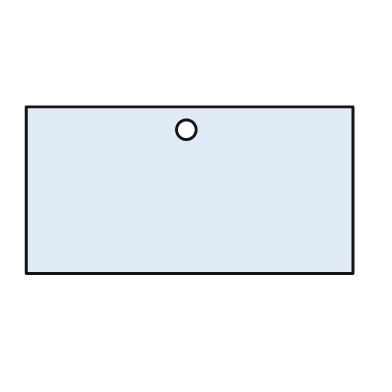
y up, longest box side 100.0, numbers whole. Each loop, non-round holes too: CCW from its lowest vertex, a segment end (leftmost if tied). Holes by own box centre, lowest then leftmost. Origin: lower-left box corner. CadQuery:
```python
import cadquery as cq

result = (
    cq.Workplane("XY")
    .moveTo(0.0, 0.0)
    .lineTo(100.0, 0.0)
    .lineTo(100.0, 51.0)
    .lineTo(0.0, 51.0)
    .close()
    .moveTo(49.0, 44.0)
    .circle(3.0)
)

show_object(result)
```